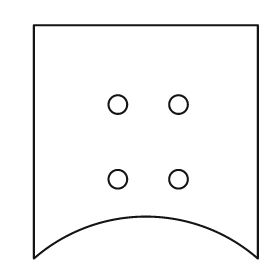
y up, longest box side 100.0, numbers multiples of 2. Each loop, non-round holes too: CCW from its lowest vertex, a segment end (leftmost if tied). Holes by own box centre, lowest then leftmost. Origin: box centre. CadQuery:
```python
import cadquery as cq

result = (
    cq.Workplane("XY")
    .moveTo(-48.0, -50.0)
    .threePointArc((0.0, -32.0), (48.0, -50.0))
    .lineTo(48.0, 50.0)
    .lineTo(-48.0, 50.0)
    .close()
    .moveTo(-12.0, -16.0)
    .circle(4.0)
    .moveTo(14.0, -16.0)
    .circle(4.0)
    .moveTo(-12.0, 16.0)
    .circle(4.0)
    .moveTo(14.0, 16.0)
    .circle(4.0)
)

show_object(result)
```